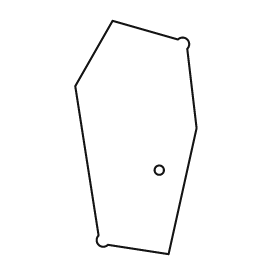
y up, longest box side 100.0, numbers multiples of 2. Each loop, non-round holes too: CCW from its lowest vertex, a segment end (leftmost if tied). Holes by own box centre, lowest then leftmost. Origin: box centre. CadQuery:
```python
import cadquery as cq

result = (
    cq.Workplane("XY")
    .moveTo(14.0, -50.0)
    .lineTo(26.0, 4.0)
    .lineTo(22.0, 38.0)
    .threePointArc((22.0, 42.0), (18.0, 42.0))
    .lineTo(-10.0, 50.0)
    .lineTo(-26.0, 22.0)
    .lineTo(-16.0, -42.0)
    .threePointArc((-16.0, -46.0), (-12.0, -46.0))
    .close()
    .moveTo(10.0, -14.0)
    .circle(2.0)
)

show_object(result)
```